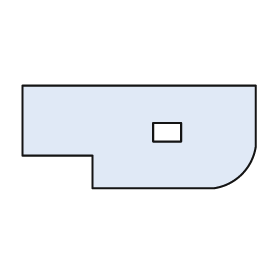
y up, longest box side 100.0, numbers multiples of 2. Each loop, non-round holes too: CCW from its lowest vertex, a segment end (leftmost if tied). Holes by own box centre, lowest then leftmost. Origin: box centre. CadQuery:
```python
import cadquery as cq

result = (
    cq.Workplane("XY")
    .moveTo(-20.0, -22.0)
    .lineTo(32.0, -22.0)
    .threePointArc((44.0, -16.0), (50.0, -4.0))
    .lineTo(50.0, 22.0)
    .lineTo(-50.0, 22.0)
    .lineTo(-50.0, -8.0)
    .lineTo(-20.0, -8.0)
    .close()
    .moveTo(6.0, -2.0)
    .lineTo(18.0, -2.0)
    .lineTo(18.0, 6.0)
    .lineTo(6.0, 6.0)
    .close()
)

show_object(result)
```